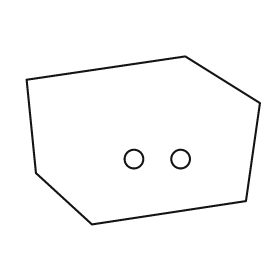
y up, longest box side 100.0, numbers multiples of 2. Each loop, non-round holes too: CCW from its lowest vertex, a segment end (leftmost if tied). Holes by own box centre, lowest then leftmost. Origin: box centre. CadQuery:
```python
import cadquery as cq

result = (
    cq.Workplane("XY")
    .moveTo(-22.0, -36.0)
    .lineTo(44.0, -26.0)
    .lineTo(50.0, 16.0)
    .lineTo(18.0, 36.0)
    .lineTo(-50.0, 26.0)
    .lineTo(-46.0, -14.0)
    .close()
    .moveTo(-4.0, -8.0)
    .circle(4.0)
    .moveTo(16.0, -8.0)
    .circle(4.0)
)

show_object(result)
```